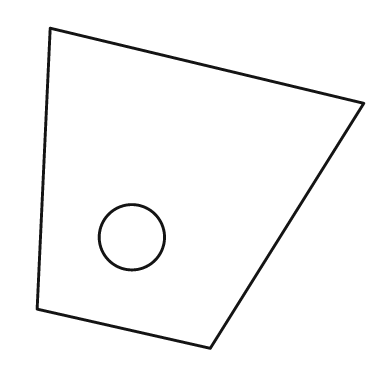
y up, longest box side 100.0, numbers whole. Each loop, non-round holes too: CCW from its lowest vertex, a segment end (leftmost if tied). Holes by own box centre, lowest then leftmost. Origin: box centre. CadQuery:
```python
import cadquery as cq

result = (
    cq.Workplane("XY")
    .moveTo(3.0, -49.0)
    .lineTo(50.0, 26.0)
    .lineTo(-46.0, 49.0)
    .lineTo(-50.0, -37.0)
    .close()
    .moveTo(-21.0, -15.0)
    .circle(10.0)
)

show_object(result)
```